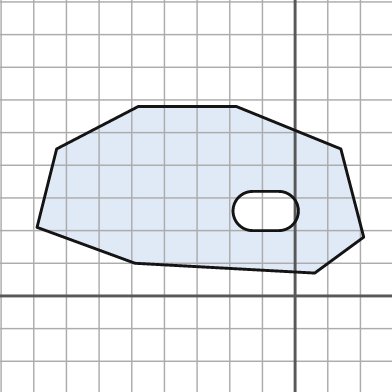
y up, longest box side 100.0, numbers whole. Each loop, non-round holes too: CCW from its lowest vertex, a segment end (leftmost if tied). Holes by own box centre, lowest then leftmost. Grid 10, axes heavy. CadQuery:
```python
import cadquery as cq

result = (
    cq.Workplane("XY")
    .moveTo(6.0, 7.0)
    .lineTo(21.0, 18.0)
    .lineTo(14.0, 45.0)
    .lineTo(-18.0, 58.0)
    .lineTo(-48.0, 58.0)
    .lineTo(-73.0, 45.0)
    .lineTo(-79.0, 21.0)
    .lineTo(-49.0, 10.0)
    .close()
    .moveTo(-13.0, 20.0)
    .lineTo(-5.0, 20.0)
    .threePointArc((1.0, 26.0), (-5.0, 32.0))
    .lineTo(-13.0, 32.0)
    .threePointArc((-19.0, 26.0), (-13.0, 20.0))
    .close()
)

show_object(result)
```